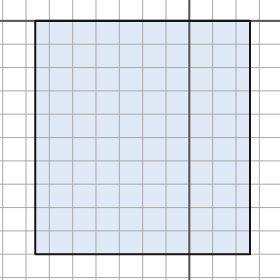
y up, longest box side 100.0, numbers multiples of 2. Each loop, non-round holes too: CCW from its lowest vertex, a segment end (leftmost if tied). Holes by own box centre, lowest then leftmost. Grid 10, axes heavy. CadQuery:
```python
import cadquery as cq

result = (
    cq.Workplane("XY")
    .moveTo(-66.0, -100.0)
    .lineTo(26.0, -100.0)
    .lineTo(26.0, 0.0)
    .lineTo(-66.0, 0.0)
    .close()
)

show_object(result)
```